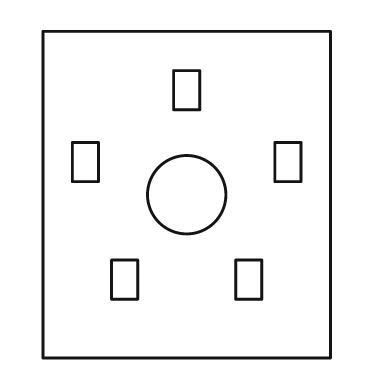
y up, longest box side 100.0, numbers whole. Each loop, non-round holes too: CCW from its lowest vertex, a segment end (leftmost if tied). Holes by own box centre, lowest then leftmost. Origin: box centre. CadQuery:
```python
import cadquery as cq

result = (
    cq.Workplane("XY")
    .moveTo(-44.0, -50.0)
    .lineTo(44.0, -50.0)
    .lineTo(44.0, 50.0)
    .lineTo(-44.0, 50.0)
    .close()
    .moveTo(-23.0, -32.0)
    .lineTo(-15.0, -32.0)
    .lineTo(-15.0, -20.0)
    .lineTo(-23.0, -20.0)
    .close()
    .moveTo(15.0, -32.0)
    .lineTo(23.0, -32.0)
    .lineTo(23.0, -20.0)
    .lineTo(15.0, -20.0)
    .close()
    .moveTo(0.0, 0.0)
    .circle(12.0)
    .moveTo(-35.0, 4.0)
    .lineTo(-27.0, 4.0)
    .lineTo(-27.0, 16.0)
    .lineTo(-35.0, 16.0)
    .close()
    .moveTo(27.0, 4.0)
    .lineTo(35.0, 4.0)
    .lineTo(35.0, 16.0)
    .lineTo(27.0, 16.0)
    .close()
    .moveTo(-4.0, 26.0)
    .lineTo(4.0, 26.0)
    .lineTo(4.0, 38.0)
    .lineTo(-4.0, 38.0)
    .close()
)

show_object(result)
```